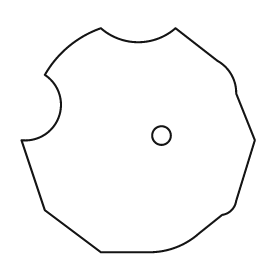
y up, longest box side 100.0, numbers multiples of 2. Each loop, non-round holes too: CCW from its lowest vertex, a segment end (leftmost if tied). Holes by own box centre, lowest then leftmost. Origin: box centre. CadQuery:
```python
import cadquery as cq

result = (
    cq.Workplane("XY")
    .moveTo(-16.0, -48.0)
    .lineTo(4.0, -48.0)
    .threePointArc((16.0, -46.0), (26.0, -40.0))
    .lineTo(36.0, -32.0)
    .threePointArc((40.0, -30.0), (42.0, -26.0))
    .lineTo(50.0, 0.0)
    .lineTo(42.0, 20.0)
    .threePointArc((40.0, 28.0), (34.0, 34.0))
    .lineTo(16.0, 48.0)
    .threePointArc((0.0, 42.0), (-16.0, 48.0))
    .threePointArc((-30.0, 40.0), (-40.0, 28.0))
    .threePointArc((-34.0, 10.0), (-50.0, 0.0))
    .lineTo(-40.0, -30.0)
    .close()
    .moveTo(10.0, 2.0)
    .circle(4.0)
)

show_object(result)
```